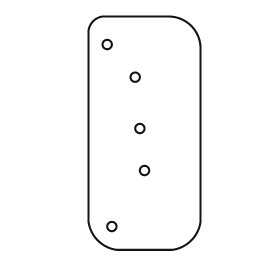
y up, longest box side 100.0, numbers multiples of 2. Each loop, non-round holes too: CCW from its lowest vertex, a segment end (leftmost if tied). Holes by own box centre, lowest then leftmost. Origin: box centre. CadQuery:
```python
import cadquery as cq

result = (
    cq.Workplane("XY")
    .moveTo(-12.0, -50.0)
    .lineTo(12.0, -50.0)
    .threePointArc((20.0, -46.0), (24.0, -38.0))
    .lineTo(24.0, 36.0)
    .threePointArc((20.0, 46.0), (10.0, 50.0))
    .lineTo(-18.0, 50.0)
    .threePointArc((-22.0, 48.0), (-24.0, 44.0))
    .lineTo(-24.0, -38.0)
    .threePointArc((-20.0, -46.0), (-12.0, -50.0))
    .close()
    .moveTo(-14.0, -40.0)
    .circle(2.0)
    .moveTo(0.0, -16.0)
    .circle(2.0)
    .moveTo(-2.0, 2.0)
    .circle(2.0)
    .moveTo(-4.0, 24.0)
    .circle(2.0)
    .moveTo(-16.0, 38.0)
    .circle(2.0)
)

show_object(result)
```